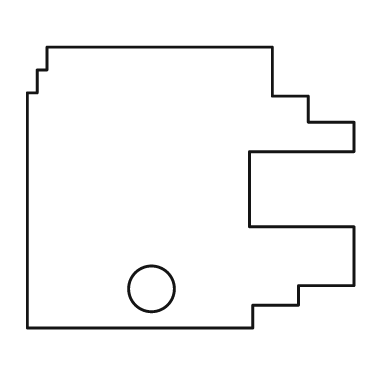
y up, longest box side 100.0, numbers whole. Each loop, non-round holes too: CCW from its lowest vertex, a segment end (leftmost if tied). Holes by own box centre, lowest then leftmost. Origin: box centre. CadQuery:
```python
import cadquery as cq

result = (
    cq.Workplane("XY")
    .moveTo(-50.0, -43.0)
    .lineTo(19.0, -43.0)
    .lineTo(19.0, -36.0)
    .lineTo(33.0, -36.0)
    .lineTo(33.0, -30.0)
    .lineTo(50.0, -30.0)
    .lineTo(50.0, -12.0)
    .lineTo(18.0, -12.0)
    .lineTo(18.0, 11.0)
    .lineTo(50.0, 11.0)
    .lineTo(50.0, 20.0)
    .lineTo(36.0, 20.0)
    .lineTo(36.0, 28.0)
    .lineTo(25.0, 28.0)
    .lineTo(25.0, 43.0)
    .lineTo(-44.0, 43.0)
    .lineTo(-44.0, 36.0)
    .lineTo(-47.0, 36.0)
    .lineTo(-47.0, 29.0)
    .lineTo(-50.0, 29.0)
    .close()
    .moveTo(-12.0, -31.0)
    .circle(7.0)
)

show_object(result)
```